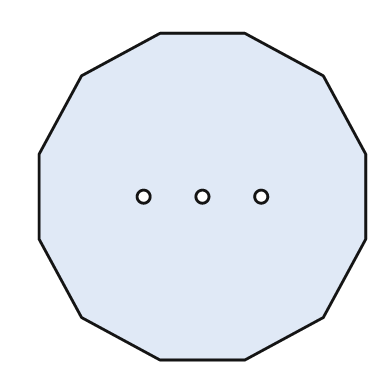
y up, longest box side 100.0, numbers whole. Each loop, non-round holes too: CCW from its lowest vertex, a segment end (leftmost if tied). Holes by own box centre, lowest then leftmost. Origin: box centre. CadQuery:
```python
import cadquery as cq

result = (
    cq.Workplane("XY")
    .moveTo(-13.0, -50.0)
    .lineTo(13.0, -50.0)
    .lineTo(37.0, -37.0)
    .lineTo(50.0, -13.0)
    .lineTo(50.0, 13.0)
    .lineTo(37.0, 37.0)
    .lineTo(13.0, 50.0)
    .lineTo(-13.0, 50.0)
    .lineTo(-37.0, 37.0)
    .lineTo(-50.0, 13.0)
    .lineTo(-50.0, -13.0)
    .lineTo(-37.0, -37.0)
    .close()
    .moveTo(-18.0, 0.0)
    .circle(2.0)
    .moveTo(0.0, 0.0)
    .circle(2.0)
    .moveTo(18.0, 0.0)
    .circle(2.0)
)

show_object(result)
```